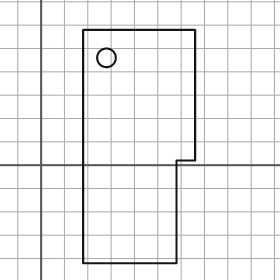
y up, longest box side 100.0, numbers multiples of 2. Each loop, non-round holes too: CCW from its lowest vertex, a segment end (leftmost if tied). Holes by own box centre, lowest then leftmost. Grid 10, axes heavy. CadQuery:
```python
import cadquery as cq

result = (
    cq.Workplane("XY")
    .moveTo(18.0, -42.0)
    .lineTo(58.0, -42.0)
    .lineTo(58.0, 2.0)
    .lineTo(66.0, 2.0)
    .lineTo(66.0, 58.0)
    .lineTo(18.0, 58.0)
    .close()
    .moveTo(28.0, 46.0)
    .circle(4.0)
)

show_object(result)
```